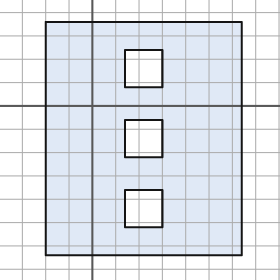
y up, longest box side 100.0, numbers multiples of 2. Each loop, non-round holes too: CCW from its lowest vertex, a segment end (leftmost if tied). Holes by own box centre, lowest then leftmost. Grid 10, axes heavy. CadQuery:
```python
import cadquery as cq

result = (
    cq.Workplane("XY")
    .moveTo(-20.0, -64.0)
    .lineTo(64.0, -64.0)
    .lineTo(64.0, 36.0)
    .lineTo(-20.0, 36.0)
    .close()
    .moveTo(14.0, -52.0)
    .lineTo(30.0, -52.0)
    .lineTo(30.0, -36.0)
    .lineTo(14.0, -36.0)
    .close()
    .moveTo(14.0, -22.0)
    .lineTo(30.0, -22.0)
    .lineTo(30.0, -6.0)
    .lineTo(14.0, -6.0)
    .close()
    .moveTo(14.0, 8.0)
    .lineTo(30.0, 8.0)
    .lineTo(30.0, 24.0)
    .lineTo(14.0, 24.0)
    .close()
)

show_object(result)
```